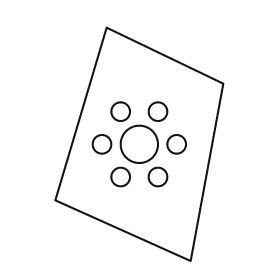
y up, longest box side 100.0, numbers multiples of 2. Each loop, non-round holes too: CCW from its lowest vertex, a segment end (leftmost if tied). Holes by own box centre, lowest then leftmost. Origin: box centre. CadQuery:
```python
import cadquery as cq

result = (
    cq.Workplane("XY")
    .moveTo(22.0, -50.0)
    .lineTo(36.0, 26.0)
    .lineTo(-14.0, 50.0)
    .lineTo(-36.0, -24.0)
    .close()
    .moveTo(-8.0, -14.0)
    .circle(4.0)
    .moveTo(8.0, -14.0)
    .circle(4.0)
    .moveTo(-16.0, 0.0)
    .circle(4.0)
    .moveTo(0.0, 0.0)
    .circle(8.0)
    .moveTo(16.0, 0.0)
    .circle(4.0)
    .moveTo(-8.0, 14.0)
    .circle(4.0)
    .moveTo(8.0, 14.0)
    .circle(4.0)
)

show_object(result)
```